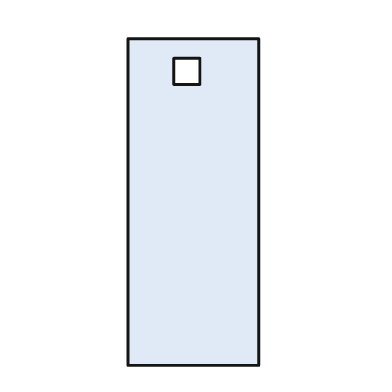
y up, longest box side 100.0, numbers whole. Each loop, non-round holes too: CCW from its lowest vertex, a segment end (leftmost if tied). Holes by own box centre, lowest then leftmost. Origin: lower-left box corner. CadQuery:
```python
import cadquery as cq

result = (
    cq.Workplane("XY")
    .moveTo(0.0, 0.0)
    .lineTo(40.0, 0.0)
    .lineTo(40.0, 100.0)
    .lineTo(0.0, 100.0)
    .close()
    .moveTo(14.0, 86.0)
    .lineTo(22.0, 86.0)
    .lineTo(22.0, 94.0)
    .lineTo(14.0, 94.0)
    .close()
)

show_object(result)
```